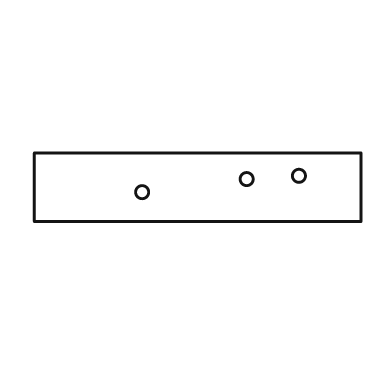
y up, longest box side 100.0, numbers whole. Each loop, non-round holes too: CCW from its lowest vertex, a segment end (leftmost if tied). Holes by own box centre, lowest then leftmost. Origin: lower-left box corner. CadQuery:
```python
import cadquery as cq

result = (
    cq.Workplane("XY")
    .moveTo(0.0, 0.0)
    .lineTo(100.0, 0.0)
    .lineTo(100.0, 21.0)
    .lineTo(0.0, 21.0)
    .close()
    .moveTo(33.0, 9.0)
    .circle(2.0)
    .moveTo(65.0, 13.0)
    .circle(2.0)
    .moveTo(81.0, 14.0)
    .circle(2.0)
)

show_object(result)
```